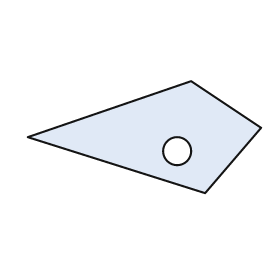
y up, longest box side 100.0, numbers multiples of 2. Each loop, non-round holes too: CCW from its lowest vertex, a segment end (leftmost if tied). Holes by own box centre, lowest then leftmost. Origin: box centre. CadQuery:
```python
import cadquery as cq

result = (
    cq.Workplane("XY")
    .moveTo(26.0, -24.0)
    .lineTo(50.0, 4.0)
    .lineTo(20.0, 24.0)
    .lineTo(-50.0, 0.0)
    .close()
    .moveTo(14.0, -6.0)
    .circle(6.0)
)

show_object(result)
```